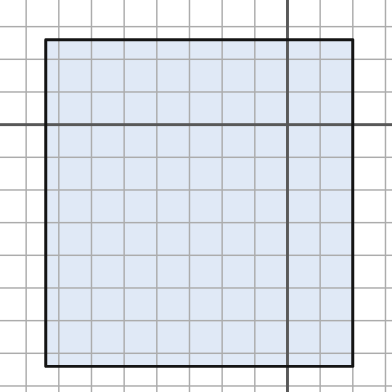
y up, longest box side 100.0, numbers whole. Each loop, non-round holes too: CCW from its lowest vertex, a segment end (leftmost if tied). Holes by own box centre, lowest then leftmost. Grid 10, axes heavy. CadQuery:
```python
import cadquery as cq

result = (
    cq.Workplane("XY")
    .moveTo(-74.0, -74.0)
    .lineTo(20.0, -74.0)
    .lineTo(20.0, 26.0)
    .lineTo(-74.0, 26.0)
    .close()
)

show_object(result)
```